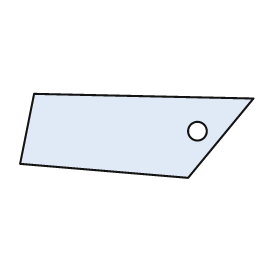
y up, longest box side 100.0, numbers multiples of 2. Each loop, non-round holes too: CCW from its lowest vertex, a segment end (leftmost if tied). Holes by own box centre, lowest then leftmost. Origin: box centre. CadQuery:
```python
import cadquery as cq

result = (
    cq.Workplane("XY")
    .moveTo(22.0, -18.0)
    .lineTo(50.0, 16.0)
    .lineTo(-44.0, 18.0)
    .lineTo(-50.0, -12.0)
    .close()
    .moveTo(26.0, 2.0)
    .circle(4.0)
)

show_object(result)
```